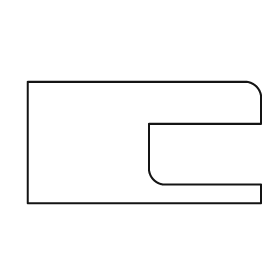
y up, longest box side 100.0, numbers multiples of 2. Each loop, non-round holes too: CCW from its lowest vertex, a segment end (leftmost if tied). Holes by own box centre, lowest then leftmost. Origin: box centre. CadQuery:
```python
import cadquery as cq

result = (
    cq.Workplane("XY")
    .moveTo(-50.0, -26.0)
    .lineTo(50.0, -26.0)
    .lineTo(50.0, -18.0)
    .lineTo(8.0, -18.0)
    .threePointArc((4.0, -16.0), (2.0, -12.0))
    .lineTo(2.0, 8.0)
    .lineTo(50.0, 8.0)
    .lineTo(50.0, 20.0)
    .threePointArc((48.0, 24.0), (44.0, 26.0))
    .lineTo(-50.0, 26.0)
    .close()
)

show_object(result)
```